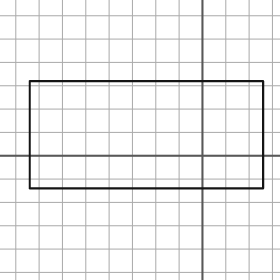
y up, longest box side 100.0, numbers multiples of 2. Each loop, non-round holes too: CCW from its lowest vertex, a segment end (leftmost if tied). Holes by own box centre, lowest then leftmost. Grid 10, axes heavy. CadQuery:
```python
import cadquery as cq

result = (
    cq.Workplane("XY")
    .moveTo(-74.0, -14.0)
    .lineTo(26.0, -14.0)
    .lineTo(26.0, 32.0)
    .lineTo(-74.0, 32.0)
    .close()
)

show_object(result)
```